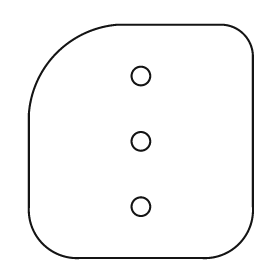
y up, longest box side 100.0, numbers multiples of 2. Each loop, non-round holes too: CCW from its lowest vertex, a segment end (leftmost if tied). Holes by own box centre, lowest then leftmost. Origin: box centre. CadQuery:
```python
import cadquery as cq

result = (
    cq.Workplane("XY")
    .moveTo(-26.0, -50.0)
    .lineTo(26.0, -50.0)
    .threePointArc((42.0, -44.0), (48.0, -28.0))
    .lineTo(48.0, 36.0)
    .threePointArc((44.0, 46.0), (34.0, 50.0))
    .lineTo(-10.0, 50.0)
    .threePointArc((-36.0, 38.0), (-48.0, 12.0))
    .lineTo(-48.0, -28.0)
    .threePointArc((-42.0, -44.0), (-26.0, -50.0))
    .close()
    .moveTo(0.0, -28.0)
    .circle(4.0)
    .moveTo(0.0, 0.0)
    .circle(4.0)
    .moveTo(0.0, 28.0)
    .circle(4.0)
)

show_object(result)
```